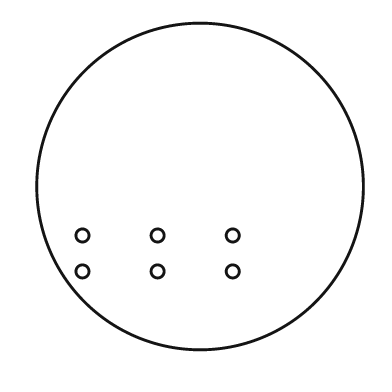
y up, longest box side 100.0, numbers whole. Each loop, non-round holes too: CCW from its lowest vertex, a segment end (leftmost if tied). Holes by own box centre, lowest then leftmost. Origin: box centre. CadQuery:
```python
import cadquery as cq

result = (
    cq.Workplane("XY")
    .moveTo(0.0, 0.0)
    .circle(50.0)
    .moveTo(-36.0, -26.0)
    .circle(2.0)
    .moveTo(-13.0, -26.0)
    .circle(2.0)
    .moveTo(10.0, -26.0)
    .circle(2.0)
    .moveTo(-36.0, -15.0)
    .circle(2.0)
    .moveTo(-13.0, -15.0)
    .circle(2.0)
    .moveTo(10.0, -15.0)
    .circle(2.0)
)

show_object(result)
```